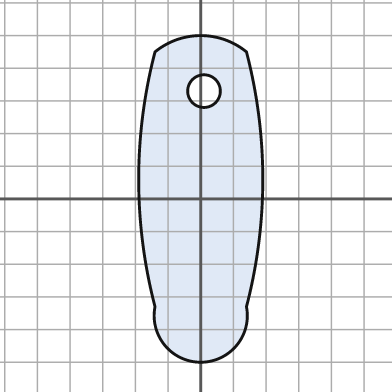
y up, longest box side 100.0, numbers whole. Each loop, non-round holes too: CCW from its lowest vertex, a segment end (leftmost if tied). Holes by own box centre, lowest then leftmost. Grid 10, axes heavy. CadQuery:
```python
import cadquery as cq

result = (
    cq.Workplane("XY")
    .moveTo(-14.0, -33.0)
    .threePointArc((0.0, -50.0), (14.0, -33.0))
    .threePointArc((19.0, 6.0), (14.0, 45.0))
    .threePointArc((0.0, 50.0), (-14.0, 45.0))
    .threePointArc((-19.0, 6.0), (-14.0, -33.0))
    .close()
    .moveTo(1.0, 33.0)
    .circle(5.0)
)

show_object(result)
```